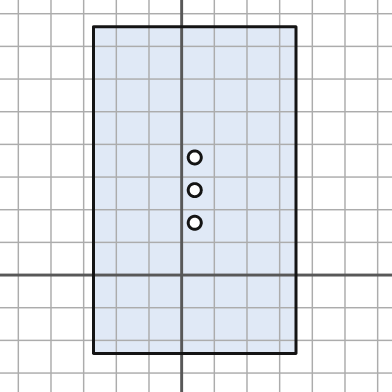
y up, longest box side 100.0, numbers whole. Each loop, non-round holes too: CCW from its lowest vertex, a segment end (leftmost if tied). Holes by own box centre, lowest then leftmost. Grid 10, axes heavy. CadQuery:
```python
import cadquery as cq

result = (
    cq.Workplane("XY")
    .moveTo(-27.0, -24.0)
    .lineTo(35.0, -24.0)
    .lineTo(35.0, 76.0)
    .lineTo(-27.0, 76.0)
    .close()
    .moveTo(4.0, 16.0)
    .circle(2.0)
    .moveTo(4.0, 26.0)
    .circle(2.0)
    .moveTo(4.0, 36.0)
    .circle(2.0)
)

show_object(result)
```